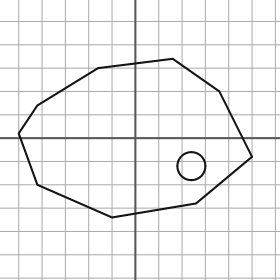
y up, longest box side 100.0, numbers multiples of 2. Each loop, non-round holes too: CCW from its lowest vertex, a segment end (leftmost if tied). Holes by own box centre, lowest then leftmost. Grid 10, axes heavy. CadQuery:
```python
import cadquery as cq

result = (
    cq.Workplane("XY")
    .moveTo(-10.0, -34.0)
    .lineTo(26.0, -28.0)
    .lineTo(50.0, -8.0)
    .lineTo(36.0, 20.0)
    .lineTo(16.0, 34.0)
    .lineTo(-16.0, 30.0)
    .lineTo(-42.0, 14.0)
    .lineTo(-50.0, 2.0)
    .lineTo(-42.0, -20.0)
    .close()
    .moveTo(24.0, -12.0)
    .circle(6.0)
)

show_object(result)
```